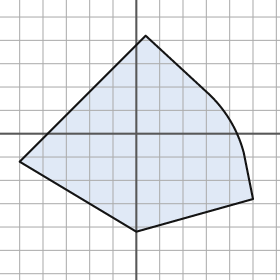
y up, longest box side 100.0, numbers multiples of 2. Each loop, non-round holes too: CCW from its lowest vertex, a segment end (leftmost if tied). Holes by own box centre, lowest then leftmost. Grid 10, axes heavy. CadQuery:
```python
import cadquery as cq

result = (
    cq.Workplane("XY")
    .moveTo(0.0, -42.0)
    .lineTo(50.0, -28.0)
    .lineTo(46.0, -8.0)
    .threePointArc((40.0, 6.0), (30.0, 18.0))
    .lineTo(4.0, 42.0)
    .lineTo(-50.0, -12.0)
    .close()
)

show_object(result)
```